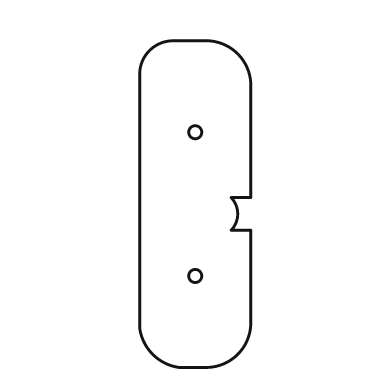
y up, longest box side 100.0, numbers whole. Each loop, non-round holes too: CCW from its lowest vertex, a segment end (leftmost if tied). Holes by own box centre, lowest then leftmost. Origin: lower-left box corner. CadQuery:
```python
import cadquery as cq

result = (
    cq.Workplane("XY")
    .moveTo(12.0, 0.0)
    .lineTo(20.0, 0.0)
    .threePointArc((30.0, 4.0), (34.0, 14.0))
    .lineTo(34.0, 42.0)
    .lineTo(28.0, 42.0)
    .threePointArc((30.0, 47.0), (28.0, 52.0))
    .lineTo(34.0, 52.0)
    .lineTo(34.0, 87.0)
    .threePointArc((30.0, 96.0), (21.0, 100.0))
    .lineTo(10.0, 100.0)
    .threePointArc((3.0, 97.0), (0.0, 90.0))
    .lineTo(0.0, 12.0)
    .threePointArc((4.0, 4.0), (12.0, 0.0))
    .close()
    .moveTo(17.0, 28.0)
    .circle(2.0)
    .moveTo(17.0, 72.0)
    .circle(2.0)
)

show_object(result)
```